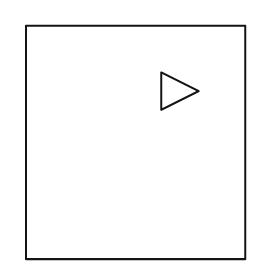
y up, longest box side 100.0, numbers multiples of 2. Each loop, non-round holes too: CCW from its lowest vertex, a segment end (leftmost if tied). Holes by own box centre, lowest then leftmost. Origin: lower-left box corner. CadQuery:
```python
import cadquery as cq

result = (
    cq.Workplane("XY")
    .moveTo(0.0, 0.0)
    .lineTo(94.0, 0.0)
    .lineTo(94.0, 100.0)
    .lineTo(0.0, 100.0)
    .close()
    .moveTo(58.0, 64.0)
    .lineTo(74.0, 72.0)
    .lineTo(58.0, 80.0)
    .close()
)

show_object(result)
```